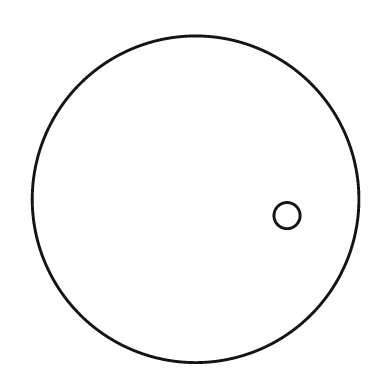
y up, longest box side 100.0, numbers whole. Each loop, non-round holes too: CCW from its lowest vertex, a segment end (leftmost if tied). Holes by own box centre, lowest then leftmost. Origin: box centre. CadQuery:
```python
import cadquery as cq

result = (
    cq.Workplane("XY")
    .moveTo(0.0, 0.0)
    .circle(50.0)
    .moveTo(28.0, -5.0)
    .circle(4.0)
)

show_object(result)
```